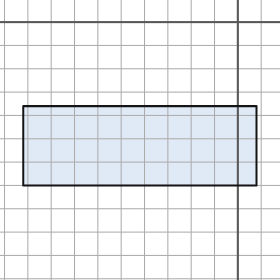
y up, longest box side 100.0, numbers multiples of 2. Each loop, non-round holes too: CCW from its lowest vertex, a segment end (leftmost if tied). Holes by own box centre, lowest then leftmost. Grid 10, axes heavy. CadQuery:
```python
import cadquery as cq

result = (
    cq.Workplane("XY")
    .moveTo(-92.0, -70.0)
    .lineTo(8.0, -70.0)
    .lineTo(8.0, -36.0)
    .lineTo(-92.0, -36.0)
    .close()
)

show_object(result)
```